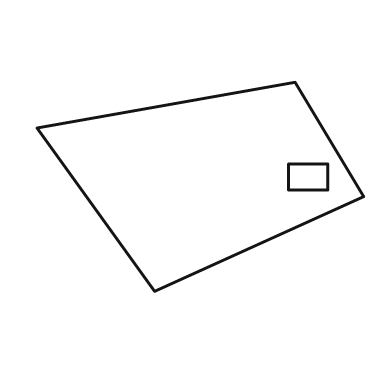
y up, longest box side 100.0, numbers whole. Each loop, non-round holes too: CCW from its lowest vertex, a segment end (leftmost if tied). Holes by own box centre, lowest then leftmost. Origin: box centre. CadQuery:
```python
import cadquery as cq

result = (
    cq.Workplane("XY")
    .moveTo(-14.0, -32.0)
    .lineTo(50.0, -3.0)
    .lineTo(29.0, 32.0)
    .lineTo(-50.0, 18.0)
    .close()
    .moveTo(27.0, -1.0)
    .lineTo(39.0, -1.0)
    .lineTo(39.0, 7.0)
    .lineTo(27.0, 7.0)
    .close()
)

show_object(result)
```